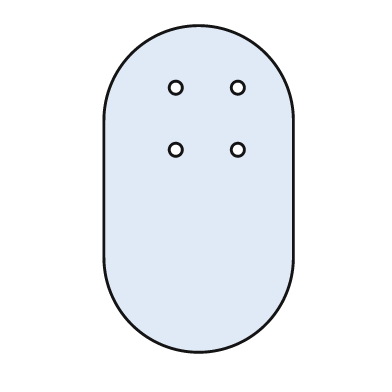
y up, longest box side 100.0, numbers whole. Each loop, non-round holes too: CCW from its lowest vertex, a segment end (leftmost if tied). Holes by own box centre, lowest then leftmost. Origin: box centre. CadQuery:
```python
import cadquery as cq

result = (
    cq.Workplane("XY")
    .moveTo(-29.0, -21.0)
    .threePointArc((0.0, -50.0), (29.0, -21.0))
    .lineTo(29.0, 21.0)
    .threePointArc((0.0, 50.0), (-29.0, 21.0))
    .close()
    .moveTo(-7.0, 12.0)
    .circle(2.0)
    .moveTo(12.0, 12.0)
    .circle(2.0)
    .moveTo(-7.0, 31.0)
    .circle(2.0)
    .moveTo(12.0, 31.0)
    .circle(2.0)
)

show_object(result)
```